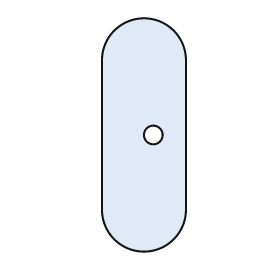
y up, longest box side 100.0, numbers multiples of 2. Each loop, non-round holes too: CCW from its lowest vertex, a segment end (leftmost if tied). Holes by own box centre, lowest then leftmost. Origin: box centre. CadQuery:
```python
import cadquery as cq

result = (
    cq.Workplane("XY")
    .moveTo(-18.0, -32.0)
    .threePointArc((0.0, -50.0), (18.0, -32.0))
    .lineTo(18.0, 32.0)
    .threePointArc((0.0, 50.0), (-18.0, 32.0))
    .close()
    .moveTo(4.0, 0.0)
    .circle(4.0)
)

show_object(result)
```